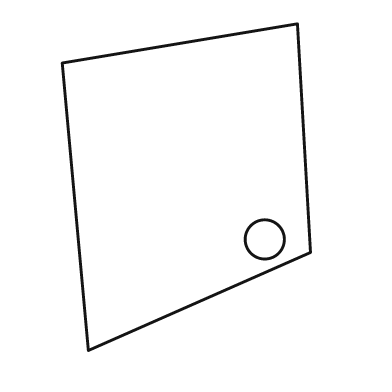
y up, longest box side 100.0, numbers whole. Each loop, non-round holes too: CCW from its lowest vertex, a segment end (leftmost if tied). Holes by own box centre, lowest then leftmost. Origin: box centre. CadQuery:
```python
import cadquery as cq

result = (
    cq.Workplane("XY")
    .moveTo(-30.0, -50.0)
    .lineTo(38.0, -20.0)
    .lineTo(34.0, 50.0)
    .lineTo(-38.0, 38.0)
    .close()
    .moveTo(24.0, -16.0)
    .circle(6.0)
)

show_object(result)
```